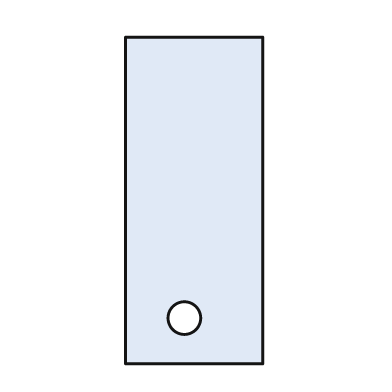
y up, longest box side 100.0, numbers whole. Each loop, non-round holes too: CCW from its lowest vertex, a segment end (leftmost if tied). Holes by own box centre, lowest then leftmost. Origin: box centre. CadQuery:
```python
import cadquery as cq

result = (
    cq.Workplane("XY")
    .moveTo(-21.0, -50.0)
    .lineTo(21.0, -50.0)
    .lineTo(21.0, 50.0)
    .lineTo(-21.0, 50.0)
    .close()
    .moveTo(-3.0, -36.0)
    .circle(5.0)
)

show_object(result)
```